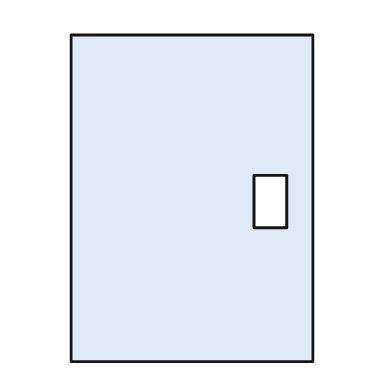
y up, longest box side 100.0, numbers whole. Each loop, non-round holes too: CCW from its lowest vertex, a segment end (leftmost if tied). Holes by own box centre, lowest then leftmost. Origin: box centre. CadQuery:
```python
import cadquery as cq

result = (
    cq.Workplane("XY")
    .moveTo(-37.0, -50.0)
    .lineTo(37.0, -50.0)
    .lineTo(37.0, 50.0)
    .lineTo(-37.0, 50.0)
    .close()
    .moveTo(19.0, -9.0)
    .lineTo(29.0, -9.0)
    .lineTo(29.0, 7.0)
    .lineTo(19.0, 7.0)
    .close()
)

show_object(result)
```